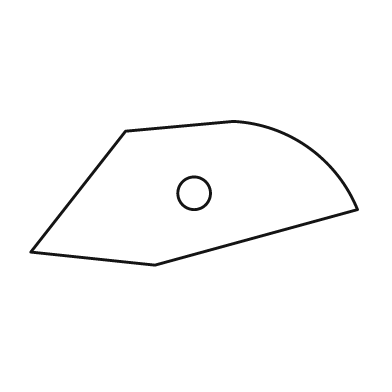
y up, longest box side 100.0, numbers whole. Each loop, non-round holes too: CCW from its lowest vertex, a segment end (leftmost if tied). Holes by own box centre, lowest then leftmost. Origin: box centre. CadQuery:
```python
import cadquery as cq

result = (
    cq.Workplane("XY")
    .moveTo(-12.0, -22.0)
    .lineTo(50.0, -5.0)
    .threePointArc((35.0, 14.0), (12.0, 22.0))
    .lineTo(-21.0, 19.0)
    .lineTo(-50.0, -18.0)
    .close()
    .moveTo(0.0, 0.0)
    .circle(5.0)
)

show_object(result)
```